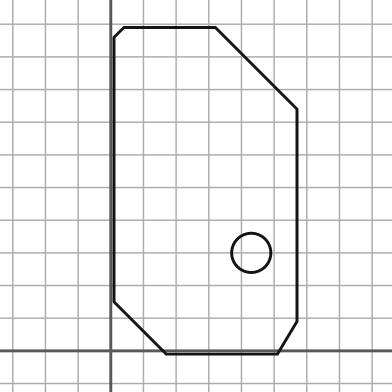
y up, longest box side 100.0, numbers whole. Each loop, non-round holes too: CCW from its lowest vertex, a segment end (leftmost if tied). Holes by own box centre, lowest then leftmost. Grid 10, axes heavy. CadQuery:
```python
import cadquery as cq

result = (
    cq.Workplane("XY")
    .moveTo(17.0, -1.0)
    .lineTo(51.0, -1.0)
    .lineTo(57.0, 9.0)
    .lineTo(57.0, 74.0)
    .lineTo(32.0, 99.0)
    .lineTo(4.0, 99.0)
    .lineTo(1.0, 96.0)
    .lineTo(1.0, 15.0)
    .close()
    .moveTo(43.0, 30.0)
    .circle(6.0)
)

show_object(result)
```